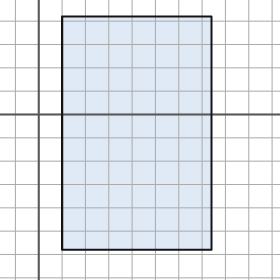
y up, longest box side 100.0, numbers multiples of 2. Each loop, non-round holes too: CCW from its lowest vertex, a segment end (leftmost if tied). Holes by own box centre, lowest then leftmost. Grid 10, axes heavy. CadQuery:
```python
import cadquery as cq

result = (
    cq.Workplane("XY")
    .moveTo(10.0, -58.0)
    .lineTo(74.0, -58.0)
    .lineTo(74.0, 42.0)
    .lineTo(10.0, 42.0)
    .close()
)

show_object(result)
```